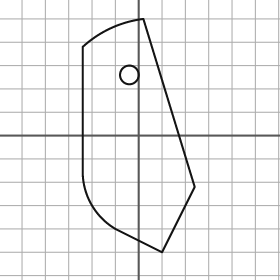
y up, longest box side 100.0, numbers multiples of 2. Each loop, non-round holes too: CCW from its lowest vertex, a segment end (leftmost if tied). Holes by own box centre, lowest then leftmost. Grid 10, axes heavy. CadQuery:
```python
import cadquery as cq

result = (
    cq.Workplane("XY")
    .moveTo(10.0, -50.0)
    .lineTo(24.0, -22.0)
    .lineTo(2.0, 50.0)
    .threePointArc((-12.0, 46.0), (-24.0, 38.0))
    .lineTo(-24.0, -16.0)
    .threePointArc((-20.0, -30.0), (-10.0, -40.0))
    .close()
    .moveTo(-4.0, 26.0)
    .circle(4.0)
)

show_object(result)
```